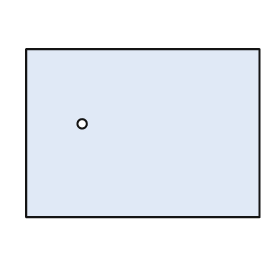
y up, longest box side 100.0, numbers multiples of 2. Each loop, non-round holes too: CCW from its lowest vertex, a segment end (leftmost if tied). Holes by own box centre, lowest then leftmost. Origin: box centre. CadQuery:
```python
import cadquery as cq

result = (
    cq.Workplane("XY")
    .moveTo(-50.0, -36.0)
    .lineTo(50.0, -36.0)
    .lineTo(50.0, 36.0)
    .lineTo(-50.0, 36.0)
    .close()
    .moveTo(-26.0, 4.0)
    .circle(2.0)
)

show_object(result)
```